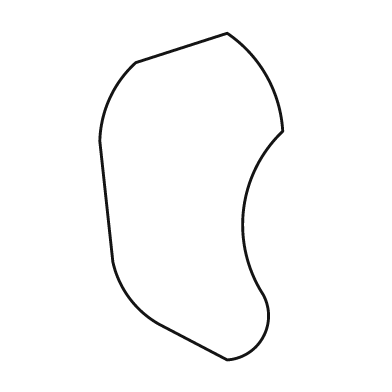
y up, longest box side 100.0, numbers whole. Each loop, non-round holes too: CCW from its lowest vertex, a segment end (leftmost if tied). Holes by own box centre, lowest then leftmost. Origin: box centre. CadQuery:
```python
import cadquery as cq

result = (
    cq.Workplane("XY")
    .moveTo(11.0, -50.0)
    .threePointArc((22.0, -43.0), (22.0, -30.0))
    .threePointArc((16.0, -4.0), (28.0, 20.0))
    .threePointArc((23.0, 37.0), (11.0, 50.0))
    .lineTo(-17.0, 41.0)
    .threePointArc((-25.0, 30.0), (-28.0, 17.0))
    .lineTo(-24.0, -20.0)
    .threePointArc((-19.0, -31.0), (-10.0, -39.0))
    .close()
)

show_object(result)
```